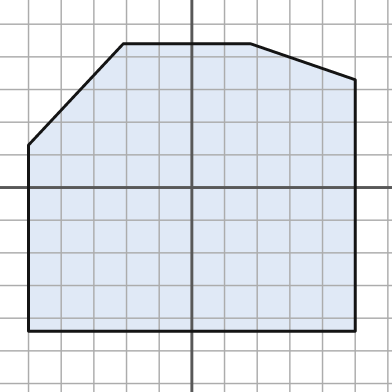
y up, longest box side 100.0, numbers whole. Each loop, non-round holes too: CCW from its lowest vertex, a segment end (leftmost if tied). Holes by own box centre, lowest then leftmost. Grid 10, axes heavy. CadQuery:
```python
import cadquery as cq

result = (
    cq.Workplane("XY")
    .moveTo(-50.0, -44.0)
    .lineTo(50.0, -44.0)
    .lineTo(50.0, 33.0)
    .lineTo(18.0, 44.0)
    .lineTo(-21.0, 44.0)
    .lineTo(-50.0, 13.0)
    .close()
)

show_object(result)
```